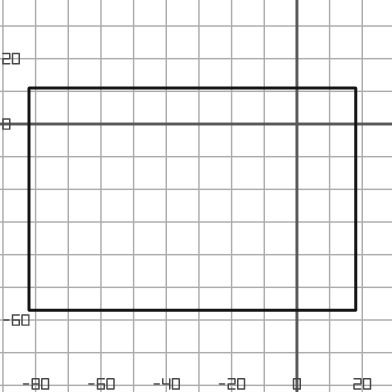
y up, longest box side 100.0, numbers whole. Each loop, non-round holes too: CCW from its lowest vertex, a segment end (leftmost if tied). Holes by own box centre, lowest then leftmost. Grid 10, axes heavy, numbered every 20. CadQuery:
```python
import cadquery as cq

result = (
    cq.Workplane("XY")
    .moveTo(-82.0, -57.0)
    .lineTo(18.0, -57.0)
    .lineTo(18.0, 11.0)
    .lineTo(-82.0, 11.0)
    .close()
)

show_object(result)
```